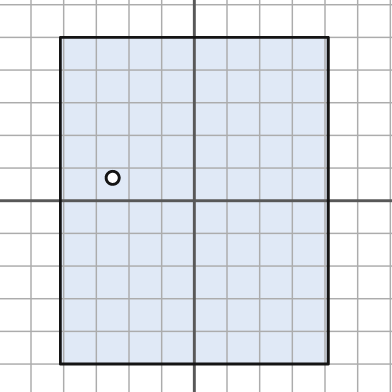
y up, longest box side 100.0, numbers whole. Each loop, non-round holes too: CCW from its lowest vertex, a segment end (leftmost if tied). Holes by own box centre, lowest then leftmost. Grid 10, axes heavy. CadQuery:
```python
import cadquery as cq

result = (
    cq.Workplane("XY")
    .moveTo(-41.0, -50.0)
    .lineTo(41.0, -50.0)
    .lineTo(41.0, 50.0)
    .lineTo(-41.0, 50.0)
    .close()
    .moveTo(-25.0, 7.0)
    .circle(2.0)
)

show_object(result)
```